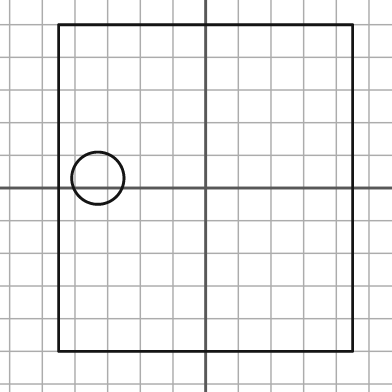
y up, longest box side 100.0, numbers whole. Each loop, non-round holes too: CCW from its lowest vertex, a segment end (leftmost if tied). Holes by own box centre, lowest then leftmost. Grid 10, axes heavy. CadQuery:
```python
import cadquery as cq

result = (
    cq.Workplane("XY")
    .moveTo(-45.0, -50.0)
    .lineTo(45.0, -50.0)
    .lineTo(45.0, 50.0)
    .lineTo(-45.0, 50.0)
    .close()
    .moveTo(-33.0, 3.0)
    .circle(8.0)
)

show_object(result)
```